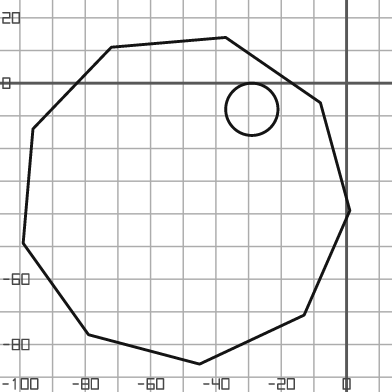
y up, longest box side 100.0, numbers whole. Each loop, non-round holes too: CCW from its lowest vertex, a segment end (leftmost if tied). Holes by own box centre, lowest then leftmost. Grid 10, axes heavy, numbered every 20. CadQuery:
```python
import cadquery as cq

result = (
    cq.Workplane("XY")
    .moveTo(-45.0, -86.0)
    .lineTo(-13.0, -71.0)
    .lineTo(1.0, -39.0)
    .lineTo(-8.0, -6.0)
    .lineTo(-37.0, 14.0)
    .lineTo(-72.0, 11.0)
    .lineTo(-96.0, -14.0)
    .lineTo(-99.0, -49.0)
    .lineTo(-79.0, -77.0)
    .close()
    .moveTo(-29.0, -8.0)
    .circle(8.0)
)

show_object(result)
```